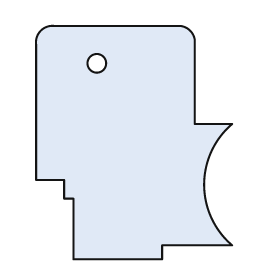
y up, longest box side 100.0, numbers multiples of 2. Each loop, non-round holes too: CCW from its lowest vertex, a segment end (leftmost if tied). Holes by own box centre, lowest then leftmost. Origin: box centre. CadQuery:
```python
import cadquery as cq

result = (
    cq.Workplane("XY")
    .moveTo(-26.0, -50.0)
    .lineTo(12.0, -50.0)
    .lineTo(12.0, -44.0)
    .lineTo(42.0, -44.0)
    .threePointArc((30.0, -18.0), (42.0, 8.0))
    .lineTo(26.0, 8.0)
    .lineTo(26.0, 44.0)
    .threePointArc((24.0, 48.0), (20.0, 50.0))
    .lineTo(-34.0, 50.0)
    .threePointArc((-40.0, 48.0), (-42.0, 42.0))
    .lineTo(-42.0, -16.0)
    .lineTo(-30.0, -16.0)
    .lineTo(-30.0, -24.0)
    .lineTo(-26.0, -24.0)
    .close()
    .moveTo(-16.0, 34.0)
    .circle(4.0)
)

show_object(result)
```